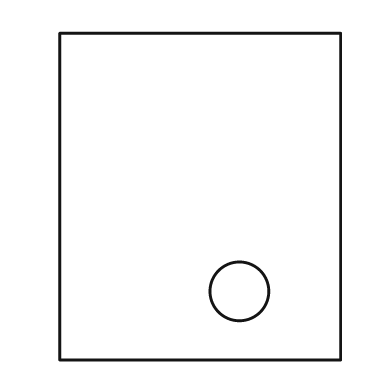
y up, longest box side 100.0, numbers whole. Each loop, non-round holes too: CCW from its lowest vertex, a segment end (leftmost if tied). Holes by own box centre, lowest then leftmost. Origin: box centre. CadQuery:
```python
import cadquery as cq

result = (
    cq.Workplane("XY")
    .moveTo(-43.0, -50.0)
    .lineTo(43.0, -50.0)
    .lineTo(43.0, 50.0)
    .lineTo(-43.0, 50.0)
    .close()
    .moveTo(12.0, -29.0)
    .circle(9.0)
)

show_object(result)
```